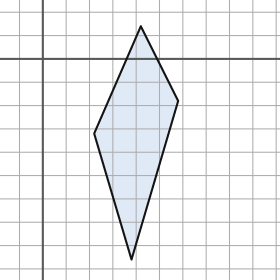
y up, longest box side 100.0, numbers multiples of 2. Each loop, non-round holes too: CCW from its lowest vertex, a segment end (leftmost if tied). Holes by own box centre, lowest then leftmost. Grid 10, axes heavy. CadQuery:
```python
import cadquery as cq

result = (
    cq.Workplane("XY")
    .moveTo(38.0, -86.0)
    .lineTo(58.0, -18.0)
    .lineTo(42.0, 14.0)
    .lineTo(22.0, -32.0)
    .close()
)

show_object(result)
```